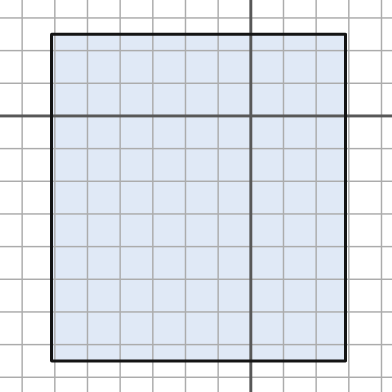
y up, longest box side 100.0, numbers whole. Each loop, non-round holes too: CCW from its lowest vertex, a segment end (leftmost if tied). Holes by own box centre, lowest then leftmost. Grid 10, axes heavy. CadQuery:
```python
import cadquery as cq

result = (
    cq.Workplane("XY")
    .moveTo(-61.0, -75.0)
    .lineTo(29.0, -75.0)
    .lineTo(29.0, 25.0)
    .lineTo(-61.0, 25.0)
    .close()
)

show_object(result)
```